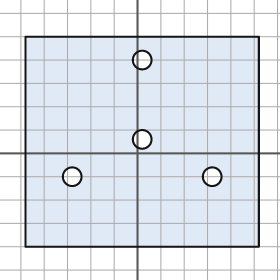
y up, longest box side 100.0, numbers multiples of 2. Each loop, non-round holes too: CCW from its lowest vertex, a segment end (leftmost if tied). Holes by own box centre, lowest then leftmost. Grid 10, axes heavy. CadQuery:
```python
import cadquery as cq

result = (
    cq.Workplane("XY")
    .moveTo(-48.0, -40.0)
    .lineTo(52.0, -40.0)
    .lineTo(52.0, 50.0)
    .lineTo(-48.0, 50.0)
    .close()
    .moveTo(-28.0, -10.0)
    .circle(4.0)
    .moveTo(32.0, -10.0)
    .circle(4.0)
    .moveTo(2.0, 6.0)
    .circle(4.0)
    .moveTo(2.0, 40.0)
    .circle(4.0)
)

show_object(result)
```